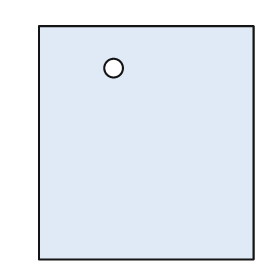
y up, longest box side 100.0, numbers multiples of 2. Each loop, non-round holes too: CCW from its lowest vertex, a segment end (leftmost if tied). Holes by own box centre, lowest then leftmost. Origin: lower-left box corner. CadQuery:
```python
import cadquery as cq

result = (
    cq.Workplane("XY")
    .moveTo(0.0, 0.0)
    .lineTo(92.0, 0.0)
    .lineTo(92.0, 100.0)
    .lineTo(0.0, 100.0)
    .close()
    .moveTo(32.0, 82.0)
    .circle(4.0)
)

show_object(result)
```